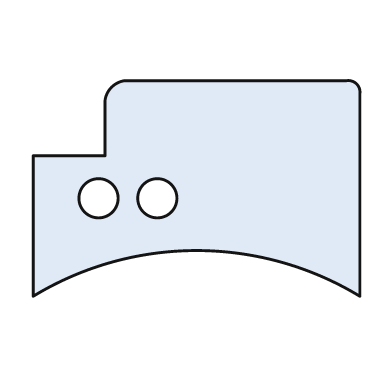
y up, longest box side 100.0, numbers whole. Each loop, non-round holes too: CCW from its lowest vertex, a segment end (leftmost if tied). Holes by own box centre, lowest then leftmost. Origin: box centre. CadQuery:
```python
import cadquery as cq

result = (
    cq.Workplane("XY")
    .moveTo(-50.0, -33.0)
    .threePointArc((0.0, -19.0), (50.0, -33.0))
    .lineTo(50.0, 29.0)
    .threePointArc((49.0, 32.0), (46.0, 33.0))
    .lineTo(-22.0, 33.0)
    .threePointArc((-26.0, 31.0), (-28.0, 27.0))
    .lineTo(-28.0, 10.0)
    .lineTo(-50.0, 10.0)
    .close()
    .moveTo(-30.0, -3.0)
    .circle(6.0)
    .moveTo(-12.0, -3.0)
    .circle(6.0)
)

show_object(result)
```